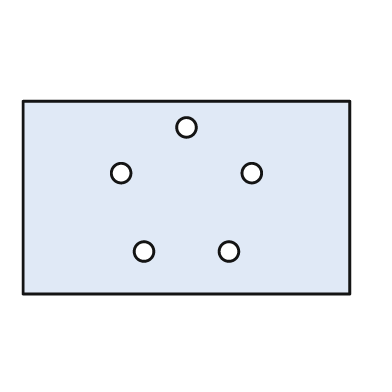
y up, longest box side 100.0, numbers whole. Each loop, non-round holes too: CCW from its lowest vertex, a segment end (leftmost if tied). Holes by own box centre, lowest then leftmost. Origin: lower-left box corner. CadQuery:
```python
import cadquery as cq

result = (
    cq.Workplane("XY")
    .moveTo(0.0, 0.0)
    .lineTo(100.0, 0.0)
    .lineTo(100.0, 59.0)
    .lineTo(0.0, 59.0)
    .close()
    .moveTo(37.0, 13.0)
    .circle(3.0)
    .moveTo(63.0, 13.0)
    .circle(3.0)
    .moveTo(30.0, 37.0)
    .circle(3.0)
    .moveTo(70.0, 37.0)
    .circle(3.0)
    .moveTo(50.0, 51.0)
    .circle(3.0)
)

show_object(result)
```